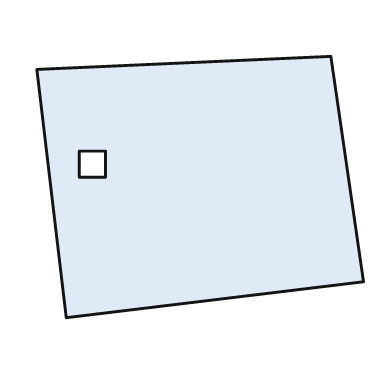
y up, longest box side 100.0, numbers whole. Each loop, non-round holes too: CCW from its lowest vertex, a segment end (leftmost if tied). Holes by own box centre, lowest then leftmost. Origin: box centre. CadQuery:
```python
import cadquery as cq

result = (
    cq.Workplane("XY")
    .moveTo(-41.0, -40.0)
    .lineTo(50.0, -29.0)
    .lineTo(40.0, 40.0)
    .lineTo(-50.0, 36.0)
    .close()
    .moveTo(-37.0, 3.0)
    .lineTo(-29.0, 3.0)
    .lineTo(-29.0, 11.0)
    .lineTo(-37.0, 11.0)
    .close()
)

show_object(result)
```